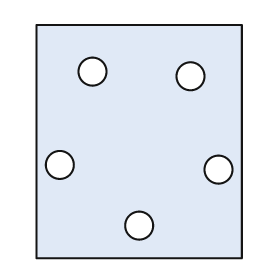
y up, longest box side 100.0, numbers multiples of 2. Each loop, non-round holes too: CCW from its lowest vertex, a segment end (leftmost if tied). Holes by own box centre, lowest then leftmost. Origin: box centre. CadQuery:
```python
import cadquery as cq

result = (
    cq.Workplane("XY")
    .moveTo(-44.0, -50.0)
    .lineTo(44.0, -50.0)
    .lineTo(44.0, 50.0)
    .lineTo(-44.0, 50.0)
    .close()
    .moveTo(0.0, -36.0)
    .circle(6.0)
    .moveTo(34.0, -12.0)
    .circle(6.0)
    .moveTo(-34.0, -10.0)
    .circle(6.0)
    .moveTo(22.0, 28.0)
    .circle(6.0)
    .moveTo(-20.0, 30.0)
    .circle(6.0)
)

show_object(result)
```